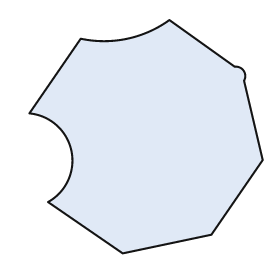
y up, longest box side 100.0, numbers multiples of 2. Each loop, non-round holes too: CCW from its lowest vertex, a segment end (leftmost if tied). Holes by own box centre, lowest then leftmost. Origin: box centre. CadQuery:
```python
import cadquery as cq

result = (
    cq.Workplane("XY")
    .moveTo(-10.0, -50.0)
    .lineTo(28.0, -42.0)
    .lineTo(50.0, -10.0)
    .lineTo(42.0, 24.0)
    .threePointArc((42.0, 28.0), (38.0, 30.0))
    .lineTo(10.0, 50.0)
    .threePointArc((-8.0, 42.0), (-28.0, 42.0))
    .lineTo(-50.0, 10.0)
    .threePointArc((-32.0, -6.0), (-42.0, -28.0))
    .close()
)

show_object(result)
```